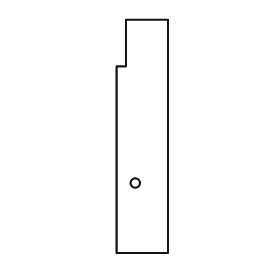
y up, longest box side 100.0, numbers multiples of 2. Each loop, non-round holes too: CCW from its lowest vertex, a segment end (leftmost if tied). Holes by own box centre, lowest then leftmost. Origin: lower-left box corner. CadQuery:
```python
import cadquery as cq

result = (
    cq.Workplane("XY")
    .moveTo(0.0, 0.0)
    .lineTo(22.0, 0.0)
    .lineTo(22.0, 100.0)
    .lineTo(4.0, 100.0)
    .lineTo(4.0, 80.0)
    .lineTo(0.0, 80.0)
    .close()
    .moveTo(8.0, 30.0)
    .circle(2.0)
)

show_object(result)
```